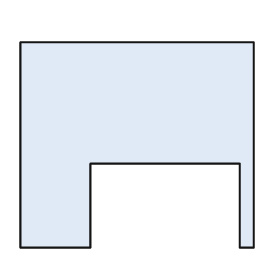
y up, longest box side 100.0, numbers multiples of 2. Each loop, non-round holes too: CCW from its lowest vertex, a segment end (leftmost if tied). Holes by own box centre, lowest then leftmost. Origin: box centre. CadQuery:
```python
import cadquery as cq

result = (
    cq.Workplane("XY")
    .moveTo(-50.0, -44.0)
    .lineTo(-20.0, -44.0)
    .lineTo(-20.0, -8.0)
    .lineTo(44.0, -8.0)
    .lineTo(44.0, -44.0)
    .lineTo(50.0, -44.0)
    .lineTo(50.0, 44.0)
    .lineTo(-50.0, 44.0)
    .close()
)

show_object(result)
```